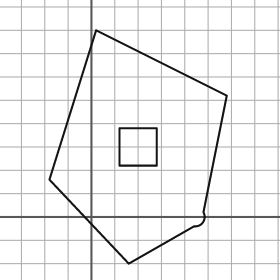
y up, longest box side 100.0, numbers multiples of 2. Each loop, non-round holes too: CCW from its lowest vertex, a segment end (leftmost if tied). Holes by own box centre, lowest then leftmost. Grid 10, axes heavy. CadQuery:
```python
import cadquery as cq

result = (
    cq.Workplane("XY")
    .moveTo(16.0, -20.0)
    .lineTo(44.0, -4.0)
    .threePointArc((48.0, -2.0), (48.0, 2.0))
    .lineTo(58.0, 52.0)
    .lineTo(2.0, 80.0)
    .lineTo(-18.0, 16.0)
    .close()
    .moveTo(12.0, 22.0)
    .lineTo(28.0, 22.0)
    .lineTo(28.0, 38.0)
    .lineTo(12.0, 38.0)
    .close()
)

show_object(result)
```